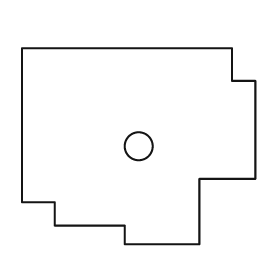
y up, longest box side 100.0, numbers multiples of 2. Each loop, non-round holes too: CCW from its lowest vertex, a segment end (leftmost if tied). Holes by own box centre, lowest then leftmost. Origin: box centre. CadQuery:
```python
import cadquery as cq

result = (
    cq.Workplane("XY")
    .moveTo(-6.0, -42.0)
    .lineTo(26.0, -42.0)
    .lineTo(26.0, -14.0)
    .lineTo(50.0, -14.0)
    .lineTo(50.0, 28.0)
    .lineTo(40.0, 28.0)
    .lineTo(40.0, 42.0)
    .lineTo(-50.0, 42.0)
    .lineTo(-50.0, -24.0)
    .lineTo(-36.0, -24.0)
    .lineTo(-36.0, -34.0)
    .lineTo(-6.0, -34.0)
    .close()
    .moveTo(0.0, 0.0)
    .circle(6.0)
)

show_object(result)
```